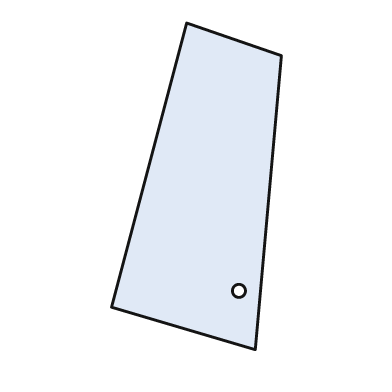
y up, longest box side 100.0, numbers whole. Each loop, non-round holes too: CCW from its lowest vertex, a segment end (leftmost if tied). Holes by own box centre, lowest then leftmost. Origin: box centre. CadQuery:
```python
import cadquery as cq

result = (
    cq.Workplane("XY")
    .moveTo(18.0, -50.0)
    .lineTo(26.0, 40.0)
    .lineTo(-3.0, 50.0)
    .lineTo(-26.0, -37.0)
    .close()
    .moveTo(13.0, -32.0)
    .circle(2.0)
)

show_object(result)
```